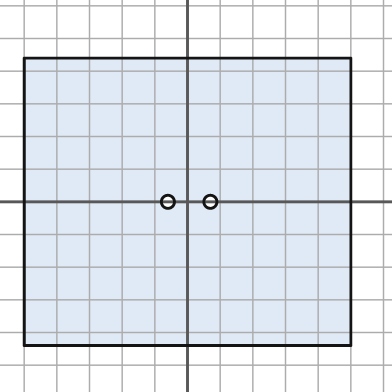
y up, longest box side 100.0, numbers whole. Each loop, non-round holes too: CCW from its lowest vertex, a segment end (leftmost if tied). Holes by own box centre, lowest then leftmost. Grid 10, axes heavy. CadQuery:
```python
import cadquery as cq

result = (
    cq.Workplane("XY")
    .moveTo(-50.0, -44.0)
    .lineTo(50.0, -44.0)
    .lineTo(50.0, 44.0)
    .lineTo(-50.0, 44.0)
    .close()
    .moveTo(-6.0, 0.0)
    .circle(2.0)
    .moveTo(7.0, 0.0)
    .circle(2.0)
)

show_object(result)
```